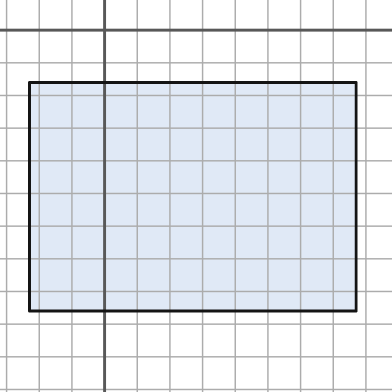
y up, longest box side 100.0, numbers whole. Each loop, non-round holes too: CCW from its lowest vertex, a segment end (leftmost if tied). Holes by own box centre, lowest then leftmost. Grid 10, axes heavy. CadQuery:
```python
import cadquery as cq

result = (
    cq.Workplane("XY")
    .moveTo(-23.0, -86.0)
    .lineTo(77.0, -86.0)
    .lineTo(77.0, -16.0)
    .lineTo(-23.0, -16.0)
    .close()
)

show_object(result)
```